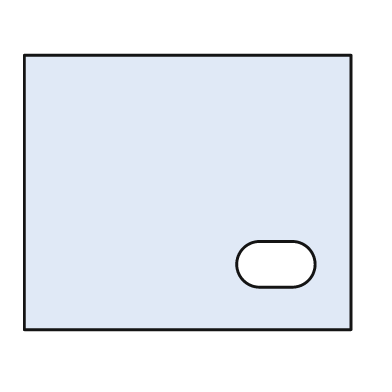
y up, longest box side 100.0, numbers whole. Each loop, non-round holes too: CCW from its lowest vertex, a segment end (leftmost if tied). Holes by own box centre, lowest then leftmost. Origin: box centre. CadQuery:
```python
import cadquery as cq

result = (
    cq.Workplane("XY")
    .moveTo(-50.0, -42.0)
    .lineTo(50.0, -42.0)
    .lineTo(50.0, 42.0)
    .lineTo(-50.0, 42.0)
    .close()
    .moveTo(22.0, -29.0)
    .lineTo(32.0, -29.0)
    .threePointArc((39.0, -22.0), (32.0, -15.0))
    .lineTo(22.0, -15.0)
    .threePointArc((15.0, -22.0), (22.0, -29.0))
    .close()
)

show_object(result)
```